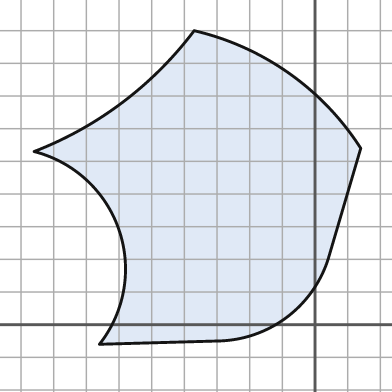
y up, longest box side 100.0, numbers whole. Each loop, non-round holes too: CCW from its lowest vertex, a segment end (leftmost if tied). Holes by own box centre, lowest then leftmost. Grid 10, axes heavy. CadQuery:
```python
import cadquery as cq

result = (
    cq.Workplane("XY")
    .moveTo(-66.0, -6.0)
    .lineTo(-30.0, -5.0)
    .threePointArc((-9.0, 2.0), (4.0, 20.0))
    .lineTo(14.0, 54.0)
    .threePointArc((-8.0, 77.0), (-37.0, 90.0))
    .threePointArc((-59.0, 68.0), (-86.0, 53.0))
    .threePointArc((-60.0, 29.0), (-66.0, -6.0))
    .close()
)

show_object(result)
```